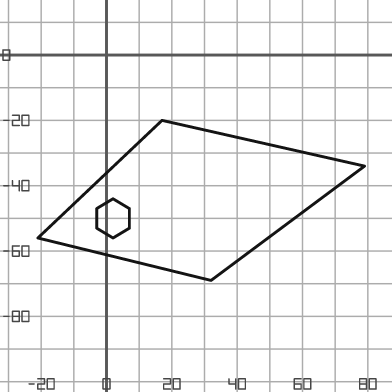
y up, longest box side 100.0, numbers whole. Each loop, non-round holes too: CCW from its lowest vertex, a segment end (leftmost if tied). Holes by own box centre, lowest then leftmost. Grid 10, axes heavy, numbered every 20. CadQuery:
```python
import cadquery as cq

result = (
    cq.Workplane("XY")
    .moveTo(32.0, -69.0)
    .lineTo(79.0, -34.0)
    .lineTo(17.0, -20.0)
    .lineTo(-21.0, -56.0)
    .close()
    .moveTo(2.0, -56.0)
    .lineTo(7.0, -53.0)
    .lineTo(7.0, -47.0)
    .lineTo(2.0, -44.0)
    .lineTo(-3.0, -47.0)
    .lineTo(-3.0, -53.0)
    .close()
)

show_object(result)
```